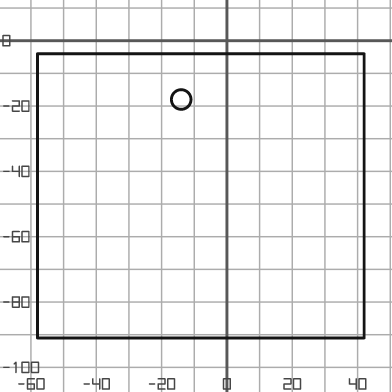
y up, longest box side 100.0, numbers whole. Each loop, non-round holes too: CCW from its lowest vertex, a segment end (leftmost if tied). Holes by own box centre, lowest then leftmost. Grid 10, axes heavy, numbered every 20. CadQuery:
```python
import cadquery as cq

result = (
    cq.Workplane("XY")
    .moveTo(-58.0, -91.0)
    .lineTo(42.0, -91.0)
    .lineTo(42.0, -4.0)
    .lineTo(-58.0, -4.0)
    .close()
    .moveTo(-14.0, -18.0)
    .circle(3.0)
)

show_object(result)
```